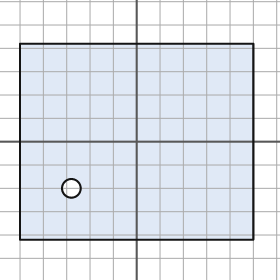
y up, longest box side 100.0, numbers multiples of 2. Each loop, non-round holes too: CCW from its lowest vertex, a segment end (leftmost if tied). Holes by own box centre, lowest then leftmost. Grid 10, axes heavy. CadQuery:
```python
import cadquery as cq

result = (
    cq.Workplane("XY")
    .moveTo(-50.0, -42.0)
    .lineTo(50.0, -42.0)
    .lineTo(50.0, 42.0)
    .lineTo(-50.0, 42.0)
    .close()
    .moveTo(-28.0, -20.0)
    .circle(4.0)
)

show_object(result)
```